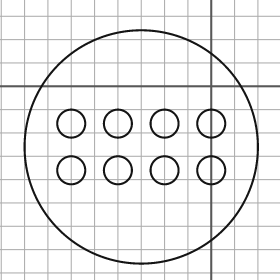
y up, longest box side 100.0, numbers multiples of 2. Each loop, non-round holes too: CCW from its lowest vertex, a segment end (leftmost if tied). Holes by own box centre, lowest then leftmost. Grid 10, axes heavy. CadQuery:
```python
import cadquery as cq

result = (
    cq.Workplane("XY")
    .moveTo(-30.0, -26.0)
    .circle(50.0)
    .moveTo(-60.0, -36.0)
    .circle(6.0)
    .moveTo(-40.0, -36.0)
    .circle(6.0)
    .moveTo(-20.0, -36.0)
    .circle(6.0)
    .moveTo(0.0, -36.0)
    .circle(6.0)
    .moveTo(-60.0, -16.0)
    .circle(6.0)
    .moveTo(-40.0, -16.0)
    .circle(6.0)
    .moveTo(-20.0, -16.0)
    .circle(6.0)
    .moveTo(0.0, -16.0)
    .circle(6.0)
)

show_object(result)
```